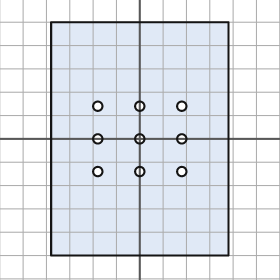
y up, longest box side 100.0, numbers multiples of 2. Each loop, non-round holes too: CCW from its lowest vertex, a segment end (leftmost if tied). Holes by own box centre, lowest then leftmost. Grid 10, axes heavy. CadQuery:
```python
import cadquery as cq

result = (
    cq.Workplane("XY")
    .moveTo(-38.0, -50.0)
    .lineTo(38.0, -50.0)
    .lineTo(38.0, 50.0)
    .lineTo(-38.0, 50.0)
    .close()
    .moveTo(-18.0, -14.0)
    .circle(2.0)
    .moveTo(0.0, -14.0)
    .circle(2.0)
    .moveTo(18.0, -14.0)
    .circle(2.0)
    .moveTo(-18.0, 0.0)
    .circle(2.0)
    .moveTo(0.0, 0.0)
    .circle(2.0)
    .moveTo(18.0, 0.0)
    .circle(2.0)
    .moveTo(-18.0, 14.0)
    .circle(2.0)
    .moveTo(0.0, 14.0)
    .circle(2.0)
    .moveTo(18.0, 14.0)
    .circle(2.0)
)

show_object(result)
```